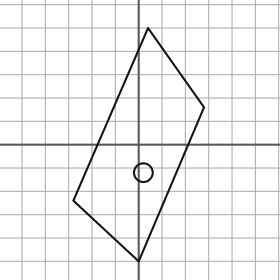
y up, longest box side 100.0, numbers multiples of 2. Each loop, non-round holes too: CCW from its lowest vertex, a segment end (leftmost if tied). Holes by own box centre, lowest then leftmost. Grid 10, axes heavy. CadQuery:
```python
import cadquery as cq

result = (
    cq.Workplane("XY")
    .moveTo(0.0, -50.0)
    .lineTo(28.0, 16.0)
    .lineTo(4.0, 50.0)
    .lineTo(-28.0, -24.0)
    .close()
    .moveTo(2.0, -12.0)
    .circle(4.0)
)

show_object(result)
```